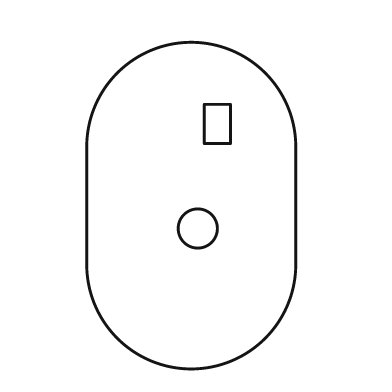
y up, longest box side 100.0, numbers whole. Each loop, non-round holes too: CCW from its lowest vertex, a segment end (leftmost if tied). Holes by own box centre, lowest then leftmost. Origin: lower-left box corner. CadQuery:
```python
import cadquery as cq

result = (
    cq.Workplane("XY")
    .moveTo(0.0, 32.0)
    .threePointArc((32.0, 0.0), (64.0, 32.0))
    .lineTo(64.0, 68.0)
    .threePointArc((32.0, 100.0), (0.0, 68.0))
    .close()
    .moveTo(34.0, 43.0)
    .circle(6.0)
    .moveTo(36.0, 69.0)
    .lineTo(44.0, 69.0)
    .lineTo(44.0, 81.0)
    .lineTo(36.0, 81.0)
    .close()
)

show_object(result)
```